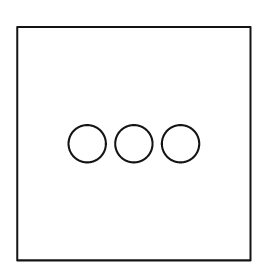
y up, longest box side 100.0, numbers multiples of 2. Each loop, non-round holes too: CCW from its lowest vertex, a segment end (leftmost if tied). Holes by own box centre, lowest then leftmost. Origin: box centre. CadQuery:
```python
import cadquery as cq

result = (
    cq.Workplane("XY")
    .moveTo(-50.0, -50.0)
    .lineTo(50.0, -50.0)
    .lineTo(50.0, 50.0)
    .lineTo(-50.0, 50.0)
    .close()
    .moveTo(-20.0, 0.0)
    .circle(8.0)
    .moveTo(0.0, 0.0)
    .circle(8.0)
    .moveTo(20.0, 0.0)
    .circle(8.0)
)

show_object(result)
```